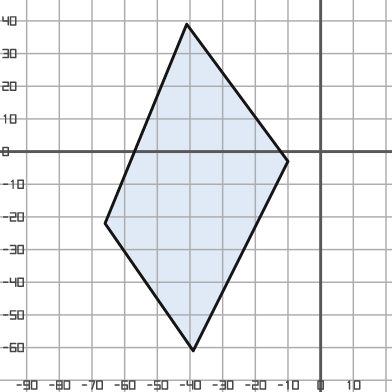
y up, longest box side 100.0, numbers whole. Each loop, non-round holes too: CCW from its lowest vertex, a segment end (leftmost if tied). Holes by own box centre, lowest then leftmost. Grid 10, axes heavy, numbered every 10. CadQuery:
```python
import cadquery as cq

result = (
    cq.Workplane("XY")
    .moveTo(-39.0, -61.0)
    .lineTo(-10.0, -3.0)
    .lineTo(-41.0, 39.0)
    .lineTo(-66.0, -22.0)
    .close()
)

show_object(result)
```